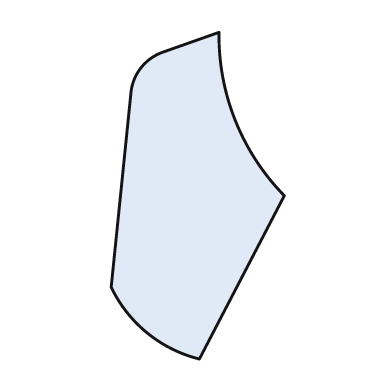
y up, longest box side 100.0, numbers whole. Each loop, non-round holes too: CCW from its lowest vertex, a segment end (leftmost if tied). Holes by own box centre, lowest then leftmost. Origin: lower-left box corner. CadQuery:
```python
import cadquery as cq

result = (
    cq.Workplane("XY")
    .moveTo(27.0, 0.0)
    .lineTo(53.0, 50.0)
    .threePointArc((38.0, 73.0), (33.0, 100.0))
    .lineTo(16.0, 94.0)
    .threePointArc((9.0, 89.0), (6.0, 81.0))
    .lineTo(0.0, 22.0)
    .threePointArc((11.0, 8.0), (27.0, 0.0))
    .close()
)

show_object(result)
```